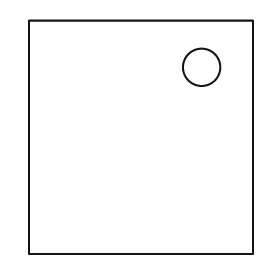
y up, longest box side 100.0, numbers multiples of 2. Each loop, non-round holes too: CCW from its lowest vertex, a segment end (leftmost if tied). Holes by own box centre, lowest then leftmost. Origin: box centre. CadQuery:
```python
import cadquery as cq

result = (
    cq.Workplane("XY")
    .moveTo(-48.0, -50.0)
    .lineTo(48.0, -50.0)
    .lineTo(48.0, 50.0)
    .lineTo(-48.0, 50.0)
    .close()
    .moveTo(26.0, 30.0)
    .circle(8.0)
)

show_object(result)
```